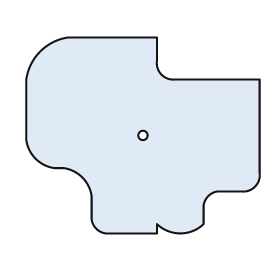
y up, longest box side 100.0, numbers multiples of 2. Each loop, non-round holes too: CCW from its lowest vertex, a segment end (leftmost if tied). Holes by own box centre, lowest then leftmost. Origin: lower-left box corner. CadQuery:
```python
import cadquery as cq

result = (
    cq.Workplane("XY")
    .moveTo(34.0, 0.0)
    .lineTo(56.0, 0.0)
    .lineTo(56.0, 4.0)
    .threePointArc((66.0, 0.0), (76.0, 4.0))
    .lineTo(76.0, 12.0)
    .threePointArc((78.0, 16.0), (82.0, 18.0))
    .lineTo(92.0, 18.0)
    .threePointArc((98.0, 20.0), (100.0, 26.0))
    .lineTo(100.0, 66.0)
    .lineTo(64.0, 66.0)
    .threePointArc((58.0, 68.0), (56.0, 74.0))
    .lineTo(56.0, 84.0)
    .lineTo(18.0, 84.0)
    .threePointArc((6.0, 78.0), (0.0, 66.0))
    .lineTo(0.0, 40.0)
    .threePointArc((4.0, 32.0), (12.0, 28.0))
    .lineTo(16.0, 28.0)
    .threePointArc((24.0, 24.0), (28.0, 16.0))
    .lineTo(28.0, 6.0)
    .threePointArc((30.0, 2.0), (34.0, 0.0))
    .close()
    .moveTo(50.0, 42.0)
    .circle(2.0)
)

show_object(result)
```